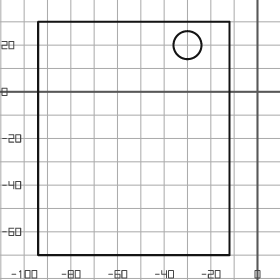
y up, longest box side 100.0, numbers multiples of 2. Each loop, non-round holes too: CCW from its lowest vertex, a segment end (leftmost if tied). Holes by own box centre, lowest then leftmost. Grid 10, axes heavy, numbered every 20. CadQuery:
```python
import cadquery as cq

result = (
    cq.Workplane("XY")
    .moveTo(-94.0, -70.0)
    .lineTo(-12.0, -70.0)
    .lineTo(-12.0, 30.0)
    .lineTo(-94.0, 30.0)
    .close()
    .moveTo(-30.0, 20.0)
    .circle(6.0)
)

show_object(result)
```